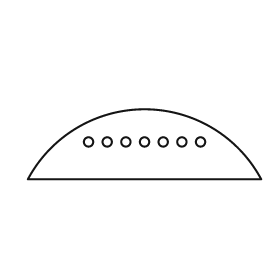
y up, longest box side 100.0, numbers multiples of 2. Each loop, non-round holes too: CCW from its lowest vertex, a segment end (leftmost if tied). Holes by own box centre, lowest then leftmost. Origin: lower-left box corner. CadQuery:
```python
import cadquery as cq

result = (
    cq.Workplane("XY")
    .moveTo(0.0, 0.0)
    .lineTo(100.0, 0.0)
    .threePointArc((50.0, 30.0), (0.0, 0.0))
    .close()
    .moveTo(26.0, 16.0)
    .circle(2.0)
    .moveTo(34.0, 16.0)
    .circle(2.0)
    .moveTo(42.0, 16.0)
    .circle(2.0)
    .moveTo(50.0, 16.0)
    .circle(2.0)
    .moveTo(58.0, 16.0)
    .circle(2.0)
    .moveTo(66.0, 16.0)
    .circle(2.0)
    .moveTo(74.0, 16.0)
    .circle(2.0)
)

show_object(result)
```